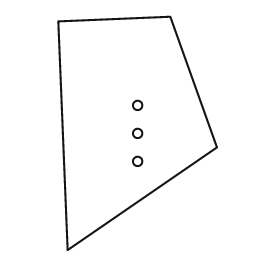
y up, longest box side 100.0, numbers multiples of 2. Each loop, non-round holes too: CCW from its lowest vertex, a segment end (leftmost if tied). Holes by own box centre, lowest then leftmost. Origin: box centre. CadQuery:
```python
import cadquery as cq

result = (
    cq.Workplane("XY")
    .moveTo(-30.0, -50.0)
    .lineTo(34.0, -6.0)
    .lineTo(14.0, 50.0)
    .lineTo(-34.0, 48.0)
    .close()
    .moveTo(0.0, -12.0)
    .circle(2.0)
    .moveTo(0.0, 0.0)
    .circle(2.0)
    .moveTo(0.0, 12.0)
    .circle(2.0)
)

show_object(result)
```